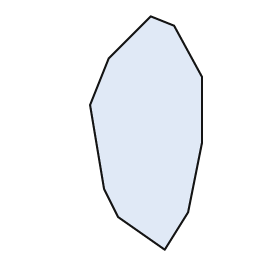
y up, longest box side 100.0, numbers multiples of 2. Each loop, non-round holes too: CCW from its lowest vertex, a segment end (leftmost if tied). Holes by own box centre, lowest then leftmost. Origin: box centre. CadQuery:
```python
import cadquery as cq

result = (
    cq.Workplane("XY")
    .moveTo(8.0, -50.0)
    .lineTo(18.0, -34.0)
    .lineTo(24.0, -4.0)
    .lineTo(24.0, 24.0)
    .lineTo(12.0, 46.0)
    .lineTo(2.0, 50.0)
    .lineTo(-16.0, 32.0)
    .lineTo(-24.0, 12.0)
    .lineTo(-18.0, -24.0)
    .lineTo(-12.0, -36.0)
    .close()
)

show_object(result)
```